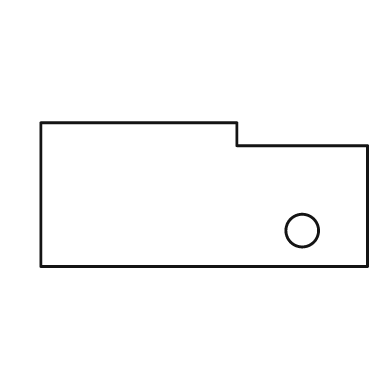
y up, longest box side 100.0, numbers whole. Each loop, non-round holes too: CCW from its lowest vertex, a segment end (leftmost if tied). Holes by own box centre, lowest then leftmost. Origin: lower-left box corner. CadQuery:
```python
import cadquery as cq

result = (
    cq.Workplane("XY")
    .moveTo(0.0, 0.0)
    .lineTo(100.0, 0.0)
    .lineTo(100.0, 37.0)
    .lineTo(60.0, 37.0)
    .lineTo(60.0, 44.0)
    .lineTo(0.0, 44.0)
    .close()
    .moveTo(80.0, 11.0)
    .circle(5.0)
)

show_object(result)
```